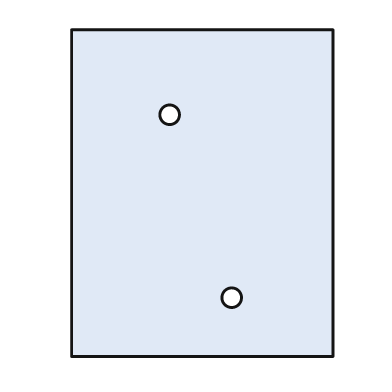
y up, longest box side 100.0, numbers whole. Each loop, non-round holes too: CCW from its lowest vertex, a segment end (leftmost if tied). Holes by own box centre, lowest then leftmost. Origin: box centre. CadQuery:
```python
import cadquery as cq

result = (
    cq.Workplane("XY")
    .moveTo(-40.0, -50.0)
    .lineTo(40.0, -50.0)
    .lineTo(40.0, 50.0)
    .lineTo(-40.0, 50.0)
    .close()
    .moveTo(9.0, -32.0)
    .circle(3.0)
    .moveTo(-10.0, 24.0)
    .circle(3.0)
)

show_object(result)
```